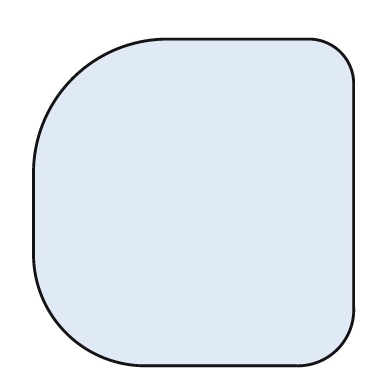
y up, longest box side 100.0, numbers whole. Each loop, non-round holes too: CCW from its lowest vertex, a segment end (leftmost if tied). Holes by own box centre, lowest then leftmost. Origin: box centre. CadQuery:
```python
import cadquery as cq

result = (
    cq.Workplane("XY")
    .moveTo(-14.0, -50.0)
    .lineTo(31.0, -50.0)
    .threePointArc((44.0, -45.0), (49.0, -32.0))
    .lineTo(49.0, 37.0)
    .threePointArc((45.0, 46.0), (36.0, 50.0))
    .lineTo(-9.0, 50.0)
    .threePointArc((-37.0, 38.0), (-49.0, 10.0))
    .lineTo(-49.0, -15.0)
    .threePointArc((-39.0, -40.0), (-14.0, -50.0))
    .close()
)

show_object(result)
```